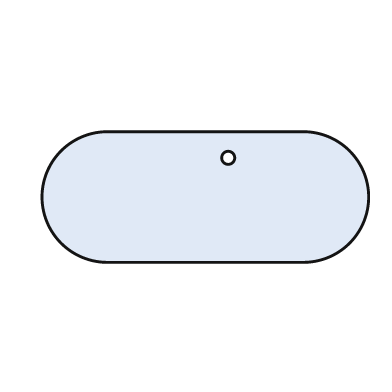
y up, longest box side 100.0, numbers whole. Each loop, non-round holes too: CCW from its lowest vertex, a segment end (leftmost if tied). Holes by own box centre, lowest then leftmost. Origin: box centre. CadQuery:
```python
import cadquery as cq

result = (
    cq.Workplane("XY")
    .moveTo(-30.0, -20.0)
    .lineTo(30.0, -20.0)
    .threePointArc((50.0, 0.0), (30.0, 20.0))
    .lineTo(-30.0, 20.0)
    .threePointArc((-50.0, 0.0), (-30.0, -20.0))
    .close()
    .moveTo(7.0, 12.0)
    .circle(2.0)
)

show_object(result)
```